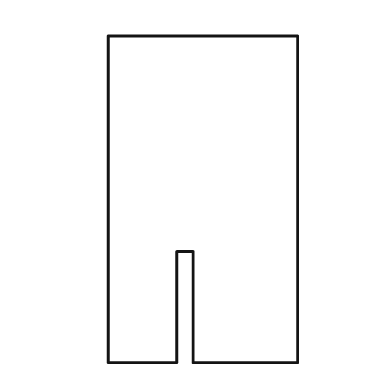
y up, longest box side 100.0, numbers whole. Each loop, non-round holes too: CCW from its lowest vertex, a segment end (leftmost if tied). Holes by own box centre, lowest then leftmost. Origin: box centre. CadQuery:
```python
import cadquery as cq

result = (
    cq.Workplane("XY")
    .moveTo(-29.0, -50.0)
    .lineTo(-8.0, -50.0)
    .lineTo(-8.0, -16.0)
    .lineTo(-3.0, -16.0)
    .lineTo(-3.0, -50.0)
    .lineTo(29.0, -50.0)
    .lineTo(29.0, 50.0)
    .lineTo(-29.0, 50.0)
    .close()
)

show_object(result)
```